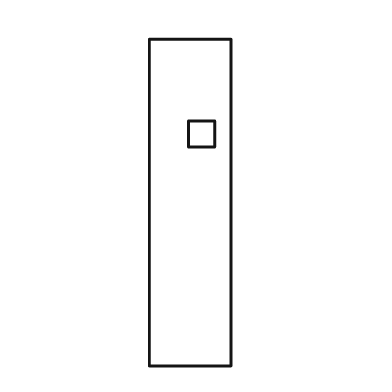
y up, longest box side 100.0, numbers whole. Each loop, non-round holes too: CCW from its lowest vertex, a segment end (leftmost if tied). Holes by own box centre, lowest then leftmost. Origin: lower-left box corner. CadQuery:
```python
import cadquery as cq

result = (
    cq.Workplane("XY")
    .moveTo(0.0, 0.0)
    .lineTo(25.0, 0.0)
    .lineTo(25.0, 100.0)
    .lineTo(0.0, 100.0)
    .close()
    .moveTo(12.0, 67.0)
    .lineTo(20.0, 67.0)
    .lineTo(20.0, 75.0)
    .lineTo(12.0, 75.0)
    .close()
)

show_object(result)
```